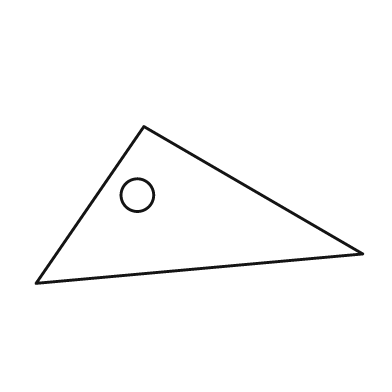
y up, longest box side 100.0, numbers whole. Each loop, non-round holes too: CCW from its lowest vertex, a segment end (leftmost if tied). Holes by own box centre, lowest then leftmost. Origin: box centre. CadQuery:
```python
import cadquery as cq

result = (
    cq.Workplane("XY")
    .moveTo(-50.0, -24.0)
    .lineTo(50.0, -15.0)
    .lineTo(-17.0, 24.0)
    .close()
    .moveTo(-19.0, 3.0)
    .circle(5.0)
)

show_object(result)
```